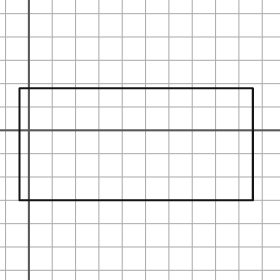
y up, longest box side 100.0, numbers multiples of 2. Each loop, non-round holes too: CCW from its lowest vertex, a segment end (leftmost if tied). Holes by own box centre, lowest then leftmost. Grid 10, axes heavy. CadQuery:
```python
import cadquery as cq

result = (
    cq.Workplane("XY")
    .moveTo(-4.0, -30.0)
    .lineTo(96.0, -30.0)
    .lineTo(96.0, 18.0)
    .lineTo(-4.0, 18.0)
    .close()
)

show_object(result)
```